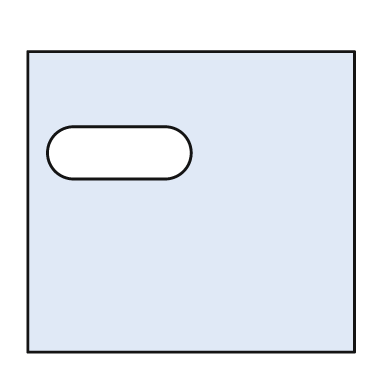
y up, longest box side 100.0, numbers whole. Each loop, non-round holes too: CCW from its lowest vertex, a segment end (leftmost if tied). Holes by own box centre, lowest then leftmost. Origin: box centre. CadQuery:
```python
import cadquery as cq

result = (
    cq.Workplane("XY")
    .moveTo(-50.0, -46.0)
    .lineTo(50.0, -46.0)
    .lineTo(50.0, 46.0)
    .lineTo(-50.0, 46.0)
    .close()
    .moveTo(-36.0, 7.0)
    .lineTo(-8.0, 7.0)
    .threePointArc((0.0, 15.0), (-8.0, 23.0))
    .lineTo(-36.0, 23.0)
    .threePointArc((-44.0, 15.0), (-36.0, 7.0))
    .close()
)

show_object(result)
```